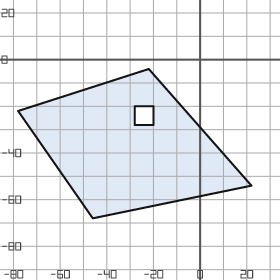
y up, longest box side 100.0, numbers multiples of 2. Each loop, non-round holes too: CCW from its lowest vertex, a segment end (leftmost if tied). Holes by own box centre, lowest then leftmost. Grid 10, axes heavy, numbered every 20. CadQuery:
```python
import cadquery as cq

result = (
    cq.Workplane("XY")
    .moveTo(-46.0, -68.0)
    .lineTo(22.0, -54.0)
    .lineTo(-22.0, -4.0)
    .lineTo(-78.0, -22.0)
    .close()
    .moveTo(-28.0, -28.0)
    .lineTo(-20.0, -28.0)
    .lineTo(-20.0, -20.0)
    .lineTo(-28.0, -20.0)
    .close()
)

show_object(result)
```